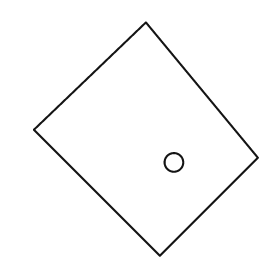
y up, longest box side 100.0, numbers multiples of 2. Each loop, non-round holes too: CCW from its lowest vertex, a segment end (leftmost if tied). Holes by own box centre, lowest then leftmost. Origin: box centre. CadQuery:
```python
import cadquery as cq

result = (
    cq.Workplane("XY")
    .moveTo(6.0, -50.0)
    .lineTo(48.0, -8.0)
    .lineTo(0.0, 50.0)
    .lineTo(-48.0, 4.0)
    .close()
    .moveTo(12.0, -10.0)
    .circle(4.0)
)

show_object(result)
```